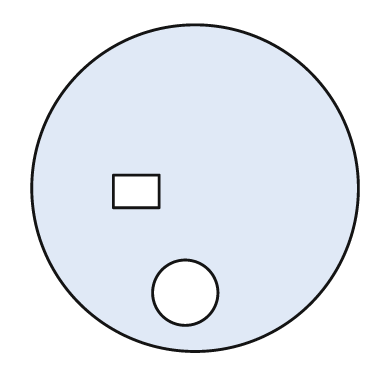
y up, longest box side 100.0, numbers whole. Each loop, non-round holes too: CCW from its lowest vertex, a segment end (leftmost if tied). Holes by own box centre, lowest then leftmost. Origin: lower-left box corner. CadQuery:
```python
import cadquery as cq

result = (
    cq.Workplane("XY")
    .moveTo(50.0, 50.0)
    .circle(50.0)
    .moveTo(47.0, 18.0)
    .circle(10.0)
    .moveTo(25.0, 44.0)
    .lineTo(39.0, 44.0)
    .lineTo(39.0, 54.0)
    .lineTo(25.0, 54.0)
    .close()
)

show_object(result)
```